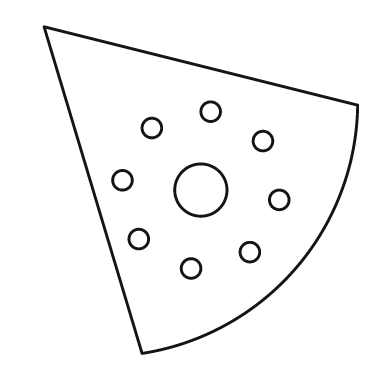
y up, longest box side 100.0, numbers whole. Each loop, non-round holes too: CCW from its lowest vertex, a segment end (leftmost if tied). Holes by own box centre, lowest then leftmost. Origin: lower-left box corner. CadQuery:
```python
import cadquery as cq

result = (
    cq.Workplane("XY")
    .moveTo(30.0, 0.0)
    .threePointArc((77.0, 26.0), (96.0, 76.0))
    .lineTo(0.0, 100.0)
    .close()
    .moveTo(45.0, 26.0)
    .circle(3.0)
    .moveTo(63.0, 31.0)
    .circle(3.0)
    .moveTo(29.0, 35.0)
    .circle(3.0)
    .moveTo(72.0, 47.0)
    .circle(3.0)
    .moveTo(48.0, 50.0)
    .circle(8.0)
    .moveTo(24.0, 53.0)
    .circle(3.0)
    .moveTo(67.0, 65.0)
    .circle(3.0)
    .moveTo(33.0, 69.0)
    .circle(3.0)
    .moveTo(51.0, 74.0)
    .circle(3.0)
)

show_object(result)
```